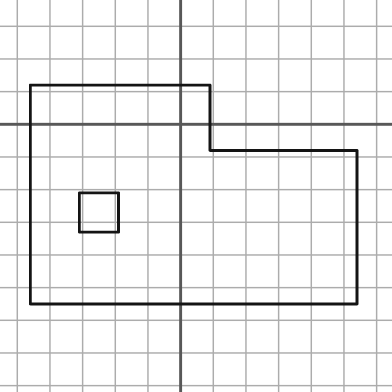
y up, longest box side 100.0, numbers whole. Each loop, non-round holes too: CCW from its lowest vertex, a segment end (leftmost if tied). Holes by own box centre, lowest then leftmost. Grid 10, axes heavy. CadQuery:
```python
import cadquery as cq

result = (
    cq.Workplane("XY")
    .moveTo(-46.0, -55.0)
    .lineTo(54.0, -55.0)
    .lineTo(54.0, -8.0)
    .lineTo(9.0, -8.0)
    .lineTo(9.0, 12.0)
    .lineTo(-46.0, 12.0)
    .close()
    .moveTo(-31.0, -33.0)
    .lineTo(-19.0, -33.0)
    .lineTo(-19.0, -21.0)
    .lineTo(-31.0, -21.0)
    .close()
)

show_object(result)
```